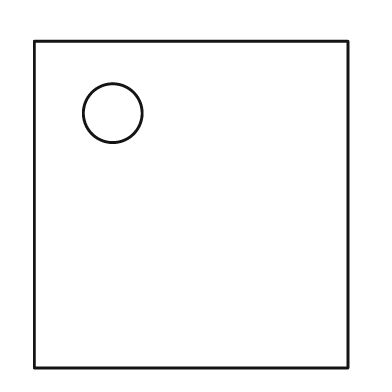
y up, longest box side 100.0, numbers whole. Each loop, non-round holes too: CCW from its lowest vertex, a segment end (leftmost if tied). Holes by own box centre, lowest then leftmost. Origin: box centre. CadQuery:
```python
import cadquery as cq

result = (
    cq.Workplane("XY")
    .moveTo(-48.0, -50.0)
    .lineTo(48.0, -50.0)
    .lineTo(48.0, 50.0)
    .lineTo(-48.0, 50.0)
    .close()
    .moveTo(-24.0, 28.0)
    .circle(9.0)
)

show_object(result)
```